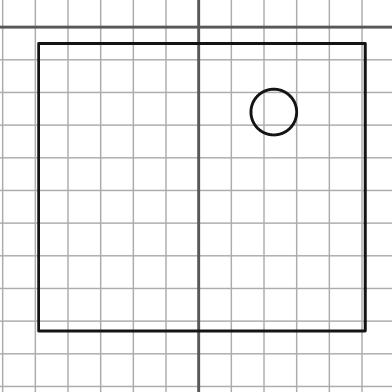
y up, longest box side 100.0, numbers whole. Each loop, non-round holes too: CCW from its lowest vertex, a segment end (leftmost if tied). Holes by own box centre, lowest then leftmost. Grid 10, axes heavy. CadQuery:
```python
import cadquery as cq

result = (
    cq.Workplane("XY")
    .moveTo(-49.0, -93.0)
    .lineTo(51.0, -93.0)
    .lineTo(51.0, -5.0)
    .lineTo(-49.0, -5.0)
    .close()
    .moveTo(23.0, -26.0)
    .circle(7.0)
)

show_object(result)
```